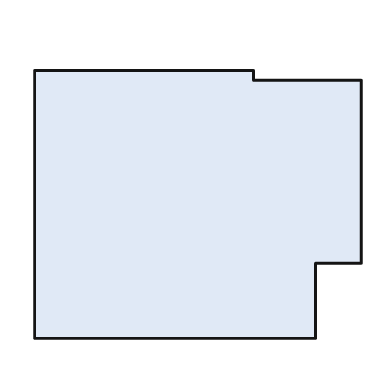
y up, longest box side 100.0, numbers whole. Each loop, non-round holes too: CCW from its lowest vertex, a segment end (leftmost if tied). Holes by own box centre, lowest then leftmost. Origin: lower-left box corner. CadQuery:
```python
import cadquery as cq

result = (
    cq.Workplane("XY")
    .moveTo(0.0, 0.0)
    .lineTo(86.0, 0.0)
    .lineTo(86.0, 23.0)
    .lineTo(100.0, 23.0)
    .lineTo(100.0, 79.0)
    .lineTo(67.0, 79.0)
    .lineTo(67.0, 82.0)
    .lineTo(0.0, 82.0)
    .close()
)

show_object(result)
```